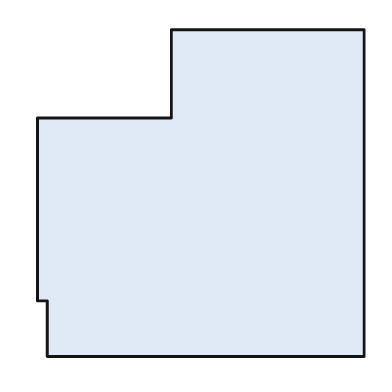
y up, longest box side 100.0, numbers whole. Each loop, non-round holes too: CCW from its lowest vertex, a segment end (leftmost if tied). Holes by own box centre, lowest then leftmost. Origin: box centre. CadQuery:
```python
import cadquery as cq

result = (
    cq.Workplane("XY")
    .moveTo(-47.0, -50.0)
    .lineTo(50.0, -50.0)
    .lineTo(50.0, 50.0)
    .lineTo(-9.0, 50.0)
    .lineTo(-9.0, 23.0)
    .lineTo(-50.0, 23.0)
    .lineTo(-50.0, -33.0)
    .lineTo(-47.0, -33.0)
    .close()
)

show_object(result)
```